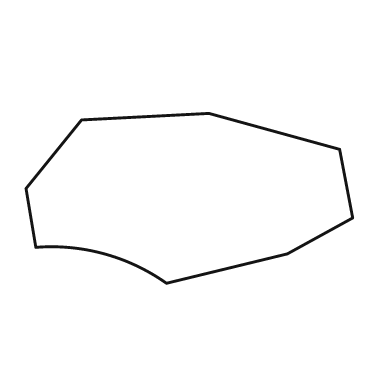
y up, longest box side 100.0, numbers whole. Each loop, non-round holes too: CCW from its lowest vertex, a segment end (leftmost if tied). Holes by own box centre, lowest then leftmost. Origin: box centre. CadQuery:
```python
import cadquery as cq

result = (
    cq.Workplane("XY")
    .moveTo(-7.0, -26.0)
    .lineTo(30.0, -17.0)
    .lineTo(50.0, -6.0)
    .lineTo(46.0, 15.0)
    .lineTo(6.0, 26.0)
    .lineTo(-33.0, 24.0)
    .lineTo(-50.0, 3.0)
    .lineTo(-47.0, -15.0)
    .threePointArc((-26.0, -17.0), (-7.0, -26.0))
    .close()
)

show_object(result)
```